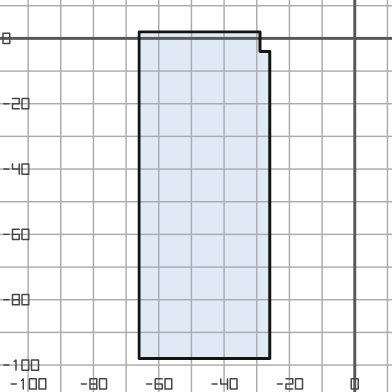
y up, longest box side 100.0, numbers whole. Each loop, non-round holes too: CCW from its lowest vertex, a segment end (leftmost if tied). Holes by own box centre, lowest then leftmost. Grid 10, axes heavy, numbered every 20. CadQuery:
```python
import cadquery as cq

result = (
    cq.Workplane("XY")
    .moveTo(-66.0, -98.0)
    .lineTo(-26.0, -98.0)
    .lineTo(-26.0, -4.0)
    .lineTo(-29.0, -4.0)
    .lineTo(-29.0, 2.0)
    .lineTo(-66.0, 2.0)
    .close()
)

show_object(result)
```